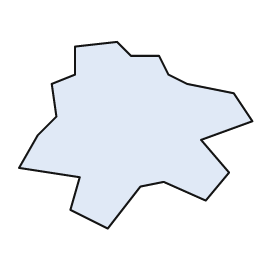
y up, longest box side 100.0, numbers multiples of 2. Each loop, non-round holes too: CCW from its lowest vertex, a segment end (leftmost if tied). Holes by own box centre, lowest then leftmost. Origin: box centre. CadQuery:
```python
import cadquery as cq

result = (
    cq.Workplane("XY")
    .moveTo(-12.0, -40.0)
    .lineTo(2.0, -22.0)
    .lineTo(12.0, -20.0)
    .lineTo(30.0, -28.0)
    .lineTo(40.0, -16.0)
    .lineTo(28.0, -2.0)
    .lineTo(50.0, 6.0)
    .lineTo(42.0, 18.0)
    .lineTo(22.0, 22.0)
    .lineTo(14.0, 26.0)
    .lineTo(10.0, 34.0)
    .lineTo(-2.0, 34.0)
    .lineTo(-8.0, 40.0)
    .lineTo(-26.0, 38.0)
    .lineTo(-26.0, 26.0)
    .lineTo(-36.0, 22.0)
    .lineTo(-34.0, 8.0)
    .lineTo(-42.0, 0.0)
    .lineTo(-50.0, -14.0)
    .lineTo(-24.0, -18.0)
    .lineTo(-28.0, -32.0)
    .close()
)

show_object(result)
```